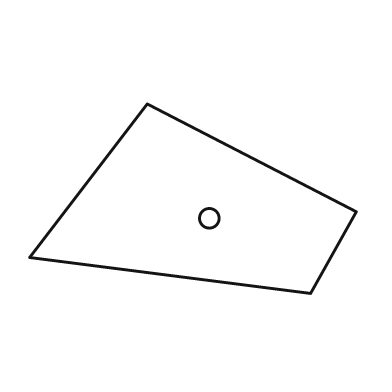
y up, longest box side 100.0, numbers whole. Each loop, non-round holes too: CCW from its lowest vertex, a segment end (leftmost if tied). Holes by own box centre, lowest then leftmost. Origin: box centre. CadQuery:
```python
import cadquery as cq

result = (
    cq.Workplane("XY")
    .moveTo(36.0, -29.0)
    .lineTo(50.0, -4.0)
    .lineTo(-14.0, 29.0)
    .lineTo(-50.0, -18.0)
    .close()
    .moveTo(5.0, -6.0)
    .circle(3.0)
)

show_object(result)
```